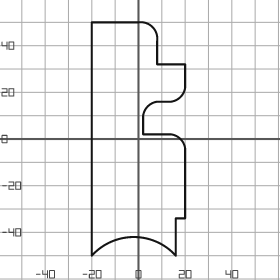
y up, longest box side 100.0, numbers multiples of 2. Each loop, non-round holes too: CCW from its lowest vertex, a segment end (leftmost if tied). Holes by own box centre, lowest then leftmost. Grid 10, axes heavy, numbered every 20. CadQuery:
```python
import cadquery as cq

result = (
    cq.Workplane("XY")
    .moveTo(-20.0, -50.0)
    .threePointArc((-2.0, -42.0), (16.0, -50.0))
    .lineTo(16.0, -34.0)
    .lineTo(20.0, -34.0)
    .lineTo(20.0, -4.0)
    .threePointArc((18.0, 0.0), (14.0, 2.0))
    .lineTo(2.0, 2.0)
    .lineTo(2.0, 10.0)
    .threePointArc((4.0, 14.0), (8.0, 16.0))
    .lineTo(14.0, 16.0)
    .threePointArc((18.0, 18.0), (20.0, 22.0))
    .lineTo(20.0, 32.0)
    .lineTo(8.0, 32.0)
    .lineTo(8.0, 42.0)
    .threePointArc((6.0, 48.0), (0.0, 50.0))
    .lineTo(-20.0, 50.0)
    .close()
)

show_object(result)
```